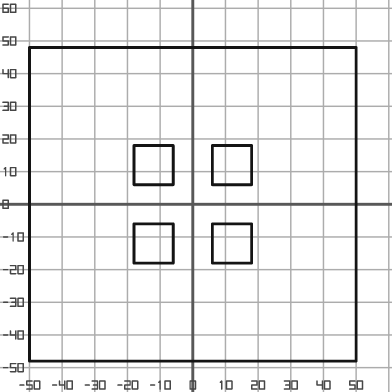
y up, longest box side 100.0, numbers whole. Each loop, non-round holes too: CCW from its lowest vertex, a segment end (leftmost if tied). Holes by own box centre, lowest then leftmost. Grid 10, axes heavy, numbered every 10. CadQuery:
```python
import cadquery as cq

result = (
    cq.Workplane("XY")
    .moveTo(-50.0, -48.0)
    .lineTo(50.0, -48.0)
    .lineTo(50.0, 48.0)
    .lineTo(-50.0, 48.0)
    .close()
    .moveTo(-18.0, -18.0)
    .lineTo(-6.0, -18.0)
    .lineTo(-6.0, -6.0)
    .lineTo(-18.0, -6.0)
    .close()
    .moveTo(6.0, -18.0)
    .lineTo(18.0, -18.0)
    .lineTo(18.0, -6.0)
    .lineTo(6.0, -6.0)
    .close()
    .moveTo(-18.0, 6.0)
    .lineTo(-6.0, 6.0)
    .lineTo(-6.0, 18.0)
    .lineTo(-18.0, 18.0)
    .close()
    .moveTo(6.0, 6.0)
    .lineTo(18.0, 6.0)
    .lineTo(18.0, 18.0)
    .lineTo(6.0, 18.0)
    .close()
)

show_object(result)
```